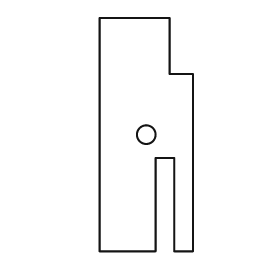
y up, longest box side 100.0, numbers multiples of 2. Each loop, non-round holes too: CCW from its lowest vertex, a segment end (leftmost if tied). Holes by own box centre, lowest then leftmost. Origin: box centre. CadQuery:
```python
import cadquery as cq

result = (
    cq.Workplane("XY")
    .moveTo(-20.0, -50.0)
    .lineTo(4.0, -50.0)
    .lineTo(4.0, -10.0)
    .lineTo(12.0, -10.0)
    .lineTo(12.0, -50.0)
    .lineTo(20.0, -50.0)
    .lineTo(20.0, 26.0)
    .lineTo(10.0, 26.0)
    .lineTo(10.0, 50.0)
    .lineTo(-20.0, 50.0)
    .close()
    .moveTo(0.0, 0.0)
    .circle(4.0)
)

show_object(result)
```